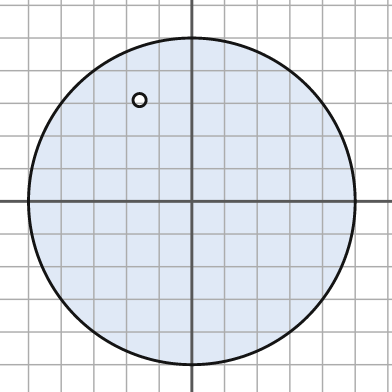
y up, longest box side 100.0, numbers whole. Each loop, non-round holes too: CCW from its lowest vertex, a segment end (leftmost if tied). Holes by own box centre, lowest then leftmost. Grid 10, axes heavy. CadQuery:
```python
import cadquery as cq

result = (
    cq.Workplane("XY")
    .moveTo(0.0, 0.0)
    .circle(50.0)
    .moveTo(-16.0, 31.0)
    .circle(2.0)
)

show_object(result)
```